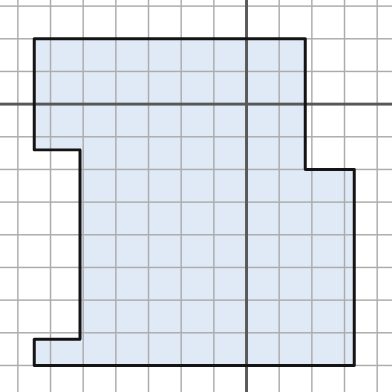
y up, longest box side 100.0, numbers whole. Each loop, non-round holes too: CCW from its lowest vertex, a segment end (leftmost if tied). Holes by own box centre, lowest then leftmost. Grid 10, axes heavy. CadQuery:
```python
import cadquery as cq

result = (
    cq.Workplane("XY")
    .moveTo(-65.0, -80.0)
    .lineTo(33.0, -80.0)
    .lineTo(33.0, -20.0)
    .lineTo(18.0, -20.0)
    .lineTo(18.0, 20.0)
    .lineTo(-65.0, 20.0)
    .lineTo(-65.0, -14.0)
    .lineTo(-51.0, -14.0)
    .lineTo(-51.0, -72.0)
    .lineTo(-65.0, -72.0)
    .close()
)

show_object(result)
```